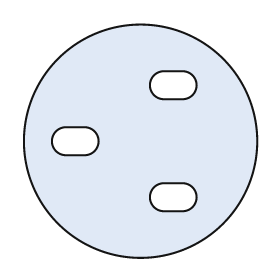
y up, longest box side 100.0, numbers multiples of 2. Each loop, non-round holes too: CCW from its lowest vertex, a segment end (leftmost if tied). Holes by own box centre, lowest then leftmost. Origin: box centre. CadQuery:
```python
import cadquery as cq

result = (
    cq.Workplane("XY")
    .moveTo(0.0, 0.0)
    .circle(50.0)
    .moveTo(10.0, -30.0)
    .lineTo(18.0, -30.0)
    .threePointArc((24.0, -24.0), (18.0, -18.0))
    .lineTo(10.0, -18.0)
    .threePointArc((4.0, -24.0), (10.0, -30.0))
    .close()
    .moveTo(-32.0, -6.0)
    .lineTo(-24.0, -6.0)
    .threePointArc((-18.0, 0.0), (-24.0, 6.0))
    .lineTo(-32.0, 6.0)
    .threePointArc((-38.0, 0.0), (-32.0, -6.0))
    .close()
    .moveTo(10.0, 18.0)
    .lineTo(18.0, 18.0)
    .threePointArc((24.0, 24.0), (18.0, 30.0))
    .lineTo(10.0, 30.0)
    .threePointArc((4.0, 24.0), (10.0, 18.0))
    .close()
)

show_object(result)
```